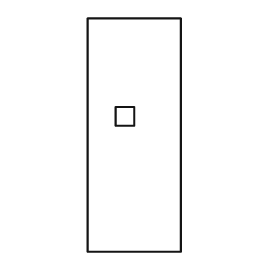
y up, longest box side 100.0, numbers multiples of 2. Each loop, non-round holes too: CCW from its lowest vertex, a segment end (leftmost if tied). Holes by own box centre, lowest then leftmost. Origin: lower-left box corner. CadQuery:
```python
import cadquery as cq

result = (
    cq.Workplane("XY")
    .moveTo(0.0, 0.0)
    .lineTo(40.0, 0.0)
    .lineTo(40.0, 100.0)
    .lineTo(0.0, 100.0)
    .close()
    .moveTo(12.0, 54.0)
    .lineTo(20.0, 54.0)
    .lineTo(20.0, 62.0)
    .lineTo(12.0, 62.0)
    .close()
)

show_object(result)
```